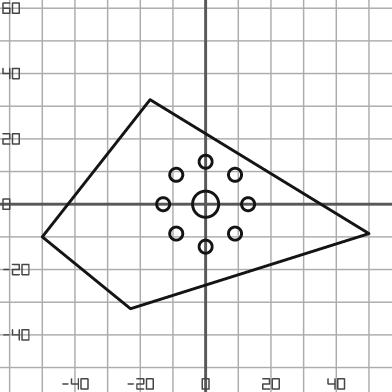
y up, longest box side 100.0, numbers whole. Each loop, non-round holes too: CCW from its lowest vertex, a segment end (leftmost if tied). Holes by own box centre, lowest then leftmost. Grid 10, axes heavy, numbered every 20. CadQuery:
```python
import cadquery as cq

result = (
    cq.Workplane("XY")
    .moveTo(-23.0, -32.0)
    .lineTo(50.0, -9.0)
    .lineTo(-17.0, 32.0)
    .lineTo(-50.0, -10.0)
    .close()
    .moveTo(0.0, -13.0)
    .circle(2.0)
    .moveTo(-9.0, -9.0)
    .circle(2.0)
    .moveTo(9.0, -9.0)
    .circle(2.0)
    .moveTo(-13.0, 0.0)
    .circle(2.0)
    .moveTo(0.0, 0.0)
    .circle(4.0)
    .moveTo(13.0, 0.0)
    .circle(2.0)
    .moveTo(-9.0, 9.0)
    .circle(2.0)
    .moveTo(9.0, 9.0)
    .circle(2.0)
    .moveTo(0.0, 13.0)
    .circle(2.0)
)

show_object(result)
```